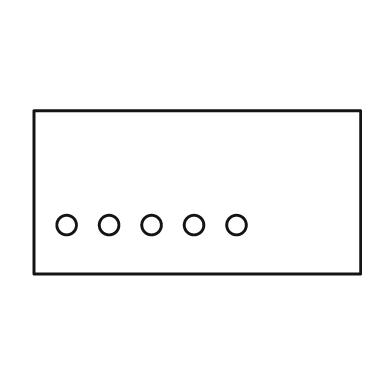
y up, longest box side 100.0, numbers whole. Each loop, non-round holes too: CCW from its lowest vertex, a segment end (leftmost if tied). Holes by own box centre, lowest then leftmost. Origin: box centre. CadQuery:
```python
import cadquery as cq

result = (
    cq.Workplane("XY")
    .moveTo(-50.0, -25.0)
    .lineTo(50.0, -25.0)
    .lineTo(50.0, 25.0)
    .lineTo(-50.0, 25.0)
    .close()
    .moveTo(-40.0, -10.0)
    .circle(3.0)
    .moveTo(-27.0, -10.0)
    .circle(3.0)
    .moveTo(-14.0, -10.0)
    .circle(3.0)
    .moveTo(-1.0, -10.0)
    .circle(3.0)
    .moveTo(12.0, -10.0)
    .circle(3.0)
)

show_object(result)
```